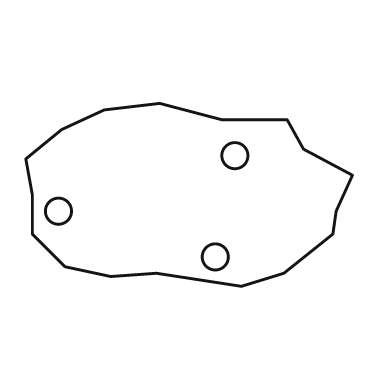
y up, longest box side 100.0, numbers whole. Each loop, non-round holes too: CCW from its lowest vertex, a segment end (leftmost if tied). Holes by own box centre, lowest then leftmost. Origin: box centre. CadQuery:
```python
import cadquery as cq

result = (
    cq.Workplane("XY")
    .moveTo(16.0, -28.0)
    .lineTo(29.0, -24.0)
    .lineTo(44.0, -12.0)
    .lineTo(45.0, -5.0)
    .lineTo(50.0, 6.0)
    .lineTo(35.0, 14.0)
    .lineTo(30.0, 23.0)
    .lineTo(10.0, 23.0)
    .lineTo(-9.0, 28.0)
    .lineTo(-26.0, 26.0)
    .lineTo(-39.0, 20.0)
    .lineTo(-50.0, 11.0)
    .lineTo(-48.0, 0.0)
    .lineTo(-48.0, -12.0)
    .lineTo(-38.0, -22.0)
    .lineTo(-24.0, -25.0)
    .lineTo(-10.0, -24.0)
    .close()
    .moveTo(8.0, -19.0)
    .circle(4.0)
    .moveTo(-40.0, -5.0)
    .circle(4.0)
    .moveTo(14.0, 12.0)
    .circle(4.0)
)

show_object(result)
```